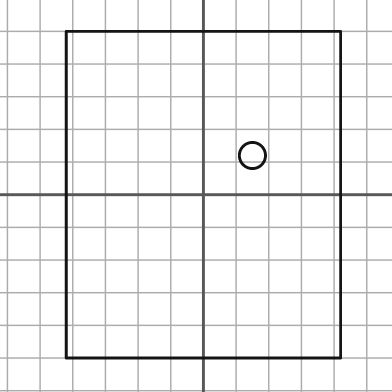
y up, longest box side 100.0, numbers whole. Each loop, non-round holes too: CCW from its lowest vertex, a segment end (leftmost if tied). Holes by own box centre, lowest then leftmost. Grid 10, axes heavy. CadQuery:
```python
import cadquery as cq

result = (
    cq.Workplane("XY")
    .moveTo(-42.0, -50.0)
    .lineTo(42.0, -50.0)
    .lineTo(42.0, 50.0)
    .lineTo(-42.0, 50.0)
    .close()
    .moveTo(15.0, 12.0)
    .circle(4.0)
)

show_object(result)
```